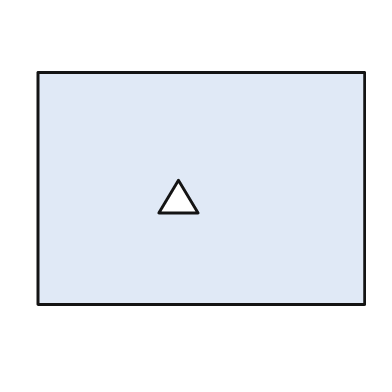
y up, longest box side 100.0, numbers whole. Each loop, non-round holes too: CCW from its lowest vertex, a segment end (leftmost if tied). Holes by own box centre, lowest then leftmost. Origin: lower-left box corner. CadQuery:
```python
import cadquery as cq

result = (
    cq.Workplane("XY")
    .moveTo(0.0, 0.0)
    .lineTo(100.0, 0.0)
    .lineTo(100.0, 71.0)
    .lineTo(0.0, 71.0)
    .close()
    .moveTo(37.0, 28.0)
    .lineTo(49.0, 28.0)
    .lineTo(43.0, 38.0)
    .close()
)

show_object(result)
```